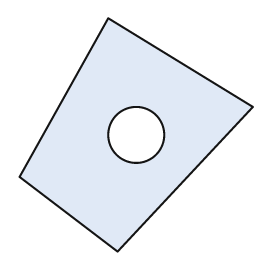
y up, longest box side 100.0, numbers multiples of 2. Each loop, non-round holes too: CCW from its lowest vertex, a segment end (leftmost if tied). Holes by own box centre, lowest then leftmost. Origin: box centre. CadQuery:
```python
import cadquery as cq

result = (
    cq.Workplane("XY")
    .moveTo(-8.0, -50.0)
    .lineTo(50.0, 12.0)
    .lineTo(-12.0, 50.0)
    .lineTo(-50.0, -18.0)
    .close()
    .moveTo(0.0, 0.0)
    .circle(12.0)
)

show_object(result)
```